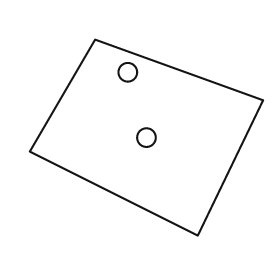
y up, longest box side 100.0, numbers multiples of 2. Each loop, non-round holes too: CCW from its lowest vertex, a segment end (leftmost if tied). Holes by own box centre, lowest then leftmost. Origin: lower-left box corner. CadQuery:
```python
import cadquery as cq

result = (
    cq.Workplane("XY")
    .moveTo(72.0, 0.0)
    .lineTo(100.0, 58.0)
    .lineTo(28.0, 84.0)
    .lineTo(0.0, 36.0)
    .close()
    .moveTo(50.0, 42.0)
    .circle(4.0)
    .moveTo(42.0, 70.0)
    .circle(4.0)
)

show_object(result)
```